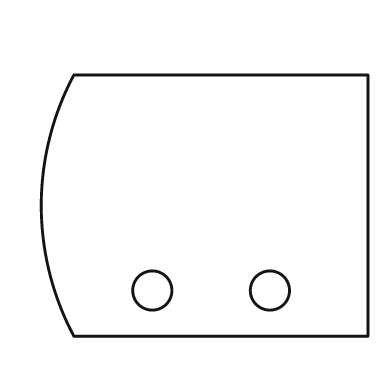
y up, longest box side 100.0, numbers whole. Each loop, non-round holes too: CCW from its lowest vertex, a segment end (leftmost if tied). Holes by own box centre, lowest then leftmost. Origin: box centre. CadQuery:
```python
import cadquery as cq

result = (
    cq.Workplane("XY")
    .moveTo(-40.0, -40.0)
    .lineTo(50.0, -40.0)
    .lineTo(50.0, 40.0)
    .lineTo(-40.0, 40.0)
    .threePointArc((-50.0, 0.0), (-40.0, -40.0))
    .close()
    .moveTo(-16.0, -26.0)
    .circle(6.0)
    .moveTo(20.0, -26.0)
    .circle(6.0)
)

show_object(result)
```